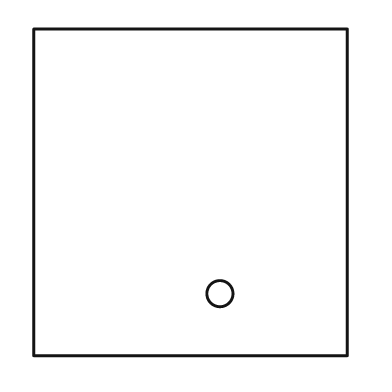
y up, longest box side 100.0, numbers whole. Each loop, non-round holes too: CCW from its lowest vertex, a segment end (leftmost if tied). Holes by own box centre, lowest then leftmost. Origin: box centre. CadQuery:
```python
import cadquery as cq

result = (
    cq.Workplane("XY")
    .moveTo(-48.0, -50.0)
    .lineTo(48.0, -50.0)
    .lineTo(48.0, 50.0)
    .lineTo(-48.0, 50.0)
    .close()
    .moveTo(9.0, -31.0)
    .circle(4.0)
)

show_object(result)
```